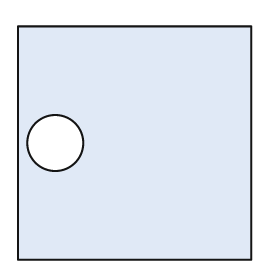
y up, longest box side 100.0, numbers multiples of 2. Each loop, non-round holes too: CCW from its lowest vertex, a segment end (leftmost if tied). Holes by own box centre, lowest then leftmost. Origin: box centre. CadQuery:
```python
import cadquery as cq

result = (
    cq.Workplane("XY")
    .moveTo(-50.0, -50.0)
    .lineTo(50.0, -50.0)
    .lineTo(50.0, 50.0)
    .lineTo(-50.0, 50.0)
    .close()
    .moveTo(-34.0, 0.0)
    .circle(12.0)
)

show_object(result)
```